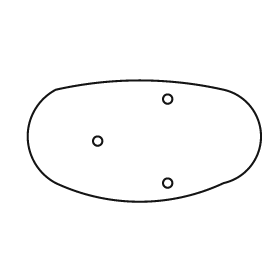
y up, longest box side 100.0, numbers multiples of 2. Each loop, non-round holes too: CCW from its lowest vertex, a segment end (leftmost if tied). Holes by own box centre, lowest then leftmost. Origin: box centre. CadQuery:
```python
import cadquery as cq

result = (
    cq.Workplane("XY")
    .moveTo(-38.0, -18.0)
    .threePointArc((-2.0, -26.0), (34.0, -18.0))
    .threePointArc((50.0, 2.0), (34.0, 22.0))
    .threePointArc((-2.0, 26.0), (-38.0, 22.0))
    .threePointArc((-50.0, 2.0), (-38.0, -18.0))
    .close()
    .moveTo(10.0, -18.0)
    .circle(2.0)
    .moveTo(-20.0, 0.0)
    .circle(2.0)
    .moveTo(10.0, 18.0)
    .circle(2.0)
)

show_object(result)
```